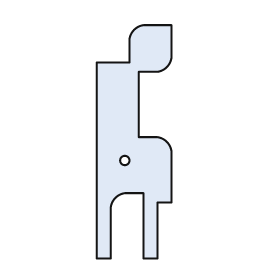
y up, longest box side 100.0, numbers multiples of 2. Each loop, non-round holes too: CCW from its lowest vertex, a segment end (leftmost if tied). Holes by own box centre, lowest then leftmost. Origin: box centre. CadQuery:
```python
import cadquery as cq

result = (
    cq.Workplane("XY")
    .moveTo(-16.0, -50.0)
    .lineTo(-10.0, -50.0)
    .lineTo(-10.0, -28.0)
    .threePointArc((-8.0, -24.0), (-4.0, -22.0))
    .lineTo(4.0, -22.0)
    .lineTo(4.0, -50.0)
    .lineTo(10.0, -50.0)
    .lineTo(10.0, -26.0)
    .lineTo(16.0, -26.0)
    .lineTo(16.0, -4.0)
    .threePointArc((14.0, 0.0), (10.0, 2.0))
    .lineTo(2.0, 2.0)
    .lineTo(2.0, 30.0)
    .lineTo(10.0, 30.0)
    .threePointArc((14.0, 32.0), (16.0, 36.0))
    .lineTo(16.0, 50.0)
    .lineTo(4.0, 50.0)
    .threePointArc((0.0, 48.0), (-2.0, 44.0))
    .lineTo(-2.0, 34.0)
    .lineTo(-16.0, 34.0)
    .close()
    .moveTo(-4.0, -8.0)
    .circle(2.0)
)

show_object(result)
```